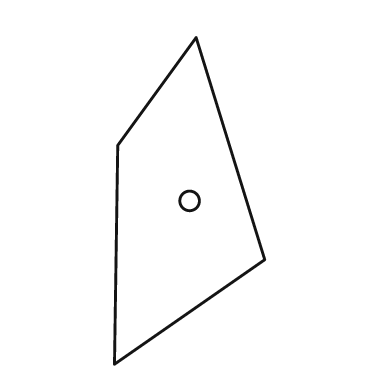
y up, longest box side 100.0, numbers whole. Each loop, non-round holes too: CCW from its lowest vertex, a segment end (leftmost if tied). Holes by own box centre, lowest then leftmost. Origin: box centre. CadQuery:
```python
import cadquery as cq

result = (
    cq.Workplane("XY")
    .moveTo(-23.0, -50.0)
    .lineTo(23.0, -18.0)
    .lineTo(2.0, 50.0)
    .lineTo(-22.0, 17.0)
    .close()
    .moveTo(0.0, 0.0)
    .circle(3.0)
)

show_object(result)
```